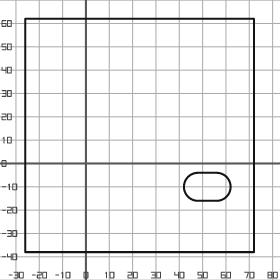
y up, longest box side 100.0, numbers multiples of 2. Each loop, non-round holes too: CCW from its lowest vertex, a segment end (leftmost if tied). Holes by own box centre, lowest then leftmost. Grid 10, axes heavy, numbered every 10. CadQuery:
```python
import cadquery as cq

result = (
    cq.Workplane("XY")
    .moveTo(-26.0, -38.0)
    .lineTo(72.0, -38.0)
    .lineTo(72.0, 62.0)
    .lineTo(-26.0, 62.0)
    .close()
    .moveTo(48.0, -16.0)
    .lineTo(56.0, -16.0)
    .threePointArc((62.0, -10.0), (56.0, -4.0))
    .lineTo(48.0, -4.0)
    .threePointArc((42.0, -10.0), (48.0, -16.0))
    .close()
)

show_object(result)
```